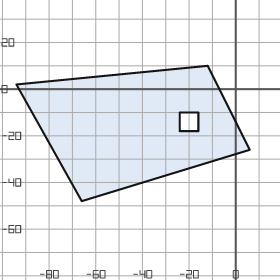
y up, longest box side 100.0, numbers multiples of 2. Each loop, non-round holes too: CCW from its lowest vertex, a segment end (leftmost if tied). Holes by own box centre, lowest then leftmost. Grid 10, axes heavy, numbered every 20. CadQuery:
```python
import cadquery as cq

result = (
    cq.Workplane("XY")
    .moveTo(-66.0, -48.0)
    .lineTo(6.0, -26.0)
    .lineTo(-12.0, 10.0)
    .lineTo(-94.0, 2.0)
    .close()
    .moveTo(-24.0, -18.0)
    .lineTo(-16.0, -18.0)
    .lineTo(-16.0, -10.0)
    .lineTo(-24.0, -10.0)
    .close()
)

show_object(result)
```